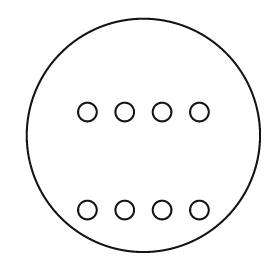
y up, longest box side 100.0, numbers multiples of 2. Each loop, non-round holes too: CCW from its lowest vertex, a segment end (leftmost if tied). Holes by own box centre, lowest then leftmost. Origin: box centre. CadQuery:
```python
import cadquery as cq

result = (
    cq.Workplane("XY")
    .moveTo(0.0, 0.0)
    .circle(50.0)
    .moveTo(-24.0, -32.0)
    .circle(4.0)
    .moveTo(-8.0, -32.0)
    .circle(4.0)
    .moveTo(8.0, -32.0)
    .circle(4.0)
    .moveTo(24.0, -32.0)
    .circle(4.0)
    .moveTo(-24.0, 10.0)
    .circle(4.0)
    .moveTo(-8.0, 10.0)
    .circle(4.0)
    .moveTo(8.0, 10.0)
    .circle(4.0)
    .moveTo(24.0, 10.0)
    .circle(4.0)
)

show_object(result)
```